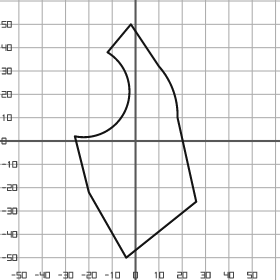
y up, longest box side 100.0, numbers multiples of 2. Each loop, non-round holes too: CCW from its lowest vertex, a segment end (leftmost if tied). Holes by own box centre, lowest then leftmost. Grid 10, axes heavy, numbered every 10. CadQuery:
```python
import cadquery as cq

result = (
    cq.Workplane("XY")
    .moveTo(-4.0, -50.0)
    .lineTo(26.0, -26.0)
    .lineTo(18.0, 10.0)
    .threePointArc((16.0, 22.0), (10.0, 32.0))
    .lineTo(-2.0, 50.0)
    .lineTo(-12.0, 38.0)
    .threePointArc((-4.0, 14.0), (-26.0, 2.0))
    .lineTo(-20.0, -22.0)
    .close()
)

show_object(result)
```